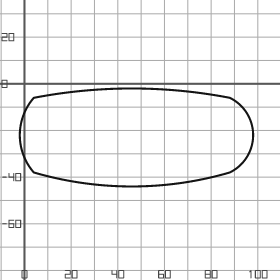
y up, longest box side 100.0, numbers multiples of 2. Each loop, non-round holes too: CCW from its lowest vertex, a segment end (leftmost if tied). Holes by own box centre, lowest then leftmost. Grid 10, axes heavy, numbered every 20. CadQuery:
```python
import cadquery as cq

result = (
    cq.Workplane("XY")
    .moveTo(4.0, -38.0)
    .threePointArc((46.0, -44.0), (88.0, -38.0))
    .threePointArc((98.0, -22.0), (88.0, -6.0))
    .threePointArc((46.0, -2.0), (4.0, -6.0))
    .threePointArc((-2.0, -22.0), (4.0, -38.0))
    .close()
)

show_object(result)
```